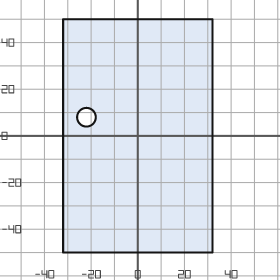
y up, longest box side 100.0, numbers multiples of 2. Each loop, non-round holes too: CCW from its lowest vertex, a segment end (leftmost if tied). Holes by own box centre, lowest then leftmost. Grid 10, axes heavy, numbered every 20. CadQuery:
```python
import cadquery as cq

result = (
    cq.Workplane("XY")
    .moveTo(-32.0, -50.0)
    .lineTo(32.0, -50.0)
    .lineTo(32.0, 50.0)
    .lineTo(-32.0, 50.0)
    .close()
    .moveTo(-22.0, 8.0)
    .circle(4.0)
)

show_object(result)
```